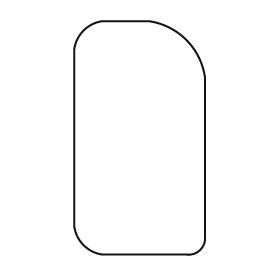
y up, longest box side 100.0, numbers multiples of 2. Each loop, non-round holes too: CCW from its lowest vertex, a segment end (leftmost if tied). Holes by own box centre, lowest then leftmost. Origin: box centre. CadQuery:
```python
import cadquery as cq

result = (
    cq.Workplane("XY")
    .moveTo(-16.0, -50.0)
    .lineTo(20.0, -50.0)
    .threePointArc((26.0, -48.0), (28.0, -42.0))
    .lineTo(28.0, 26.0)
    .threePointArc((20.0, 42.0), (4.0, 50.0))
    .lineTo(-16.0, 50.0)
    .threePointArc((-24.0, 46.0), (-28.0, 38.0))
    .lineTo(-28.0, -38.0)
    .threePointArc((-24.0, -46.0), (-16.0, -50.0))
    .close()
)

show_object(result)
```